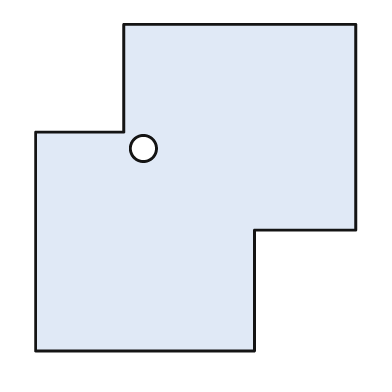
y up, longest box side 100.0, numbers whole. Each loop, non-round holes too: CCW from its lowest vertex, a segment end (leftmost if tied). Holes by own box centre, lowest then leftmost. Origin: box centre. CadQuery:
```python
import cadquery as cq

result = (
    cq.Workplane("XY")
    .moveTo(-49.0, -50.0)
    .lineTo(18.0, -50.0)
    .lineTo(18.0, -13.0)
    .lineTo(49.0, -13.0)
    .lineTo(49.0, 50.0)
    .lineTo(-22.0, 50.0)
    .lineTo(-22.0, 17.0)
    .lineTo(-49.0, 17.0)
    .close()
    .moveTo(-16.0, 12.0)
    .circle(4.0)
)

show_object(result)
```